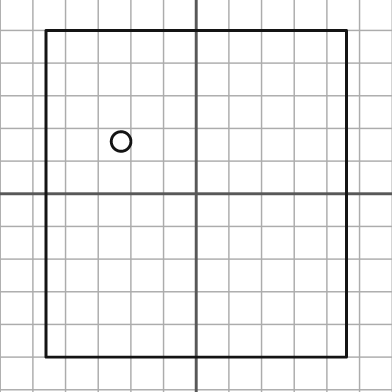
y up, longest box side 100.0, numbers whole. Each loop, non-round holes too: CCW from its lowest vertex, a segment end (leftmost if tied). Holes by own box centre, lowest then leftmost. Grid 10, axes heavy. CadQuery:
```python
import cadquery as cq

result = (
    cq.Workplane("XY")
    .moveTo(-46.0, -50.0)
    .lineTo(46.0, -50.0)
    .lineTo(46.0, 50.0)
    .lineTo(-46.0, 50.0)
    .close()
    .moveTo(-23.0, 16.0)
    .circle(3.0)
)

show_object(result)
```